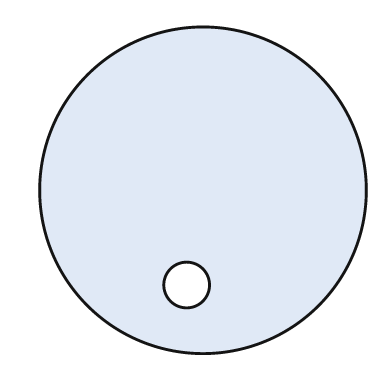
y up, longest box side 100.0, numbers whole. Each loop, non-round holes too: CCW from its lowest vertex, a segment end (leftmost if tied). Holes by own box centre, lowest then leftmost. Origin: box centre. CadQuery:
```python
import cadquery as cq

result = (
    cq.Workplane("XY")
    .moveTo(0.0, 0.0)
    .circle(50.0)
    .moveTo(-5.0, -29.0)
    .circle(7.0)
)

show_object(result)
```